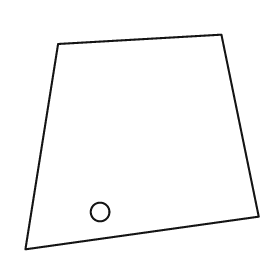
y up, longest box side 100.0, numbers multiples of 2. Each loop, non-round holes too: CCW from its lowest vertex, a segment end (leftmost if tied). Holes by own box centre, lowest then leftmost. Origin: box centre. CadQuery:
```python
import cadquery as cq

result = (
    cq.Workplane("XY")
    .moveTo(-50.0, -46.0)
    .lineTo(50.0, -32.0)
    .lineTo(34.0, 46.0)
    .lineTo(-36.0, 42.0)
    .close()
    .moveTo(-18.0, -30.0)
    .circle(4.0)
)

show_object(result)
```